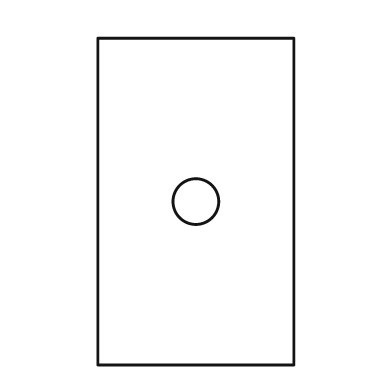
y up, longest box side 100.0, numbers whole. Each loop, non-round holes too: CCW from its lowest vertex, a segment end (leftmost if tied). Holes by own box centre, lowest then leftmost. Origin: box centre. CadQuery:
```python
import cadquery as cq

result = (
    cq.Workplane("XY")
    .moveTo(-30.0, -50.0)
    .lineTo(30.0, -50.0)
    .lineTo(30.0, 50.0)
    .lineTo(-30.0, 50.0)
    .close()
    .moveTo(0.0, 0.0)
    .circle(7.0)
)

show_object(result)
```